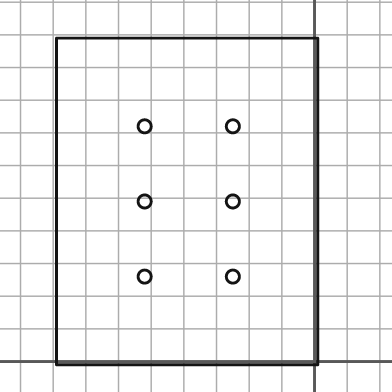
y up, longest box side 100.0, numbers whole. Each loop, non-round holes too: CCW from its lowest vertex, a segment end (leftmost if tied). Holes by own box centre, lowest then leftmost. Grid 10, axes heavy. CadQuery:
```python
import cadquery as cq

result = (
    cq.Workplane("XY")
    .moveTo(-79.0, -1.0)
    .lineTo(1.0, -1.0)
    .lineTo(1.0, 99.0)
    .lineTo(-79.0, 99.0)
    .close()
    .moveTo(-52.0, 26.0)
    .circle(2.0)
    .moveTo(-25.0, 26.0)
    .circle(2.0)
    .moveTo(-52.0, 49.0)
    .circle(2.0)
    .moveTo(-25.0, 49.0)
    .circle(2.0)
    .moveTo(-52.0, 72.0)
    .circle(2.0)
    .moveTo(-25.0, 72.0)
    .circle(2.0)
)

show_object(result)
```